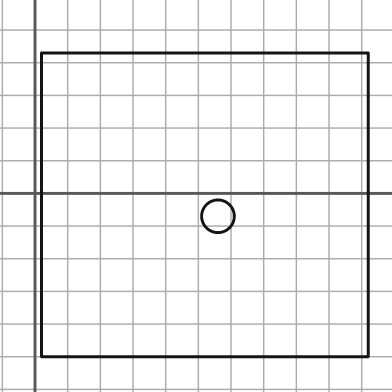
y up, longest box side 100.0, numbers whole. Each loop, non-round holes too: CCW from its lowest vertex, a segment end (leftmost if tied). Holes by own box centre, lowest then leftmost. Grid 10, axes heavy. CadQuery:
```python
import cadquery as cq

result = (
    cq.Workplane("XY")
    .moveTo(2.0, -50.0)
    .lineTo(102.0, -50.0)
    .lineTo(102.0, 43.0)
    .lineTo(2.0, 43.0)
    .close()
    .moveTo(56.0, -7.0)
    .circle(5.0)
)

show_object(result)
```